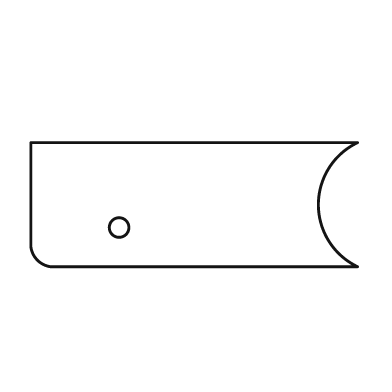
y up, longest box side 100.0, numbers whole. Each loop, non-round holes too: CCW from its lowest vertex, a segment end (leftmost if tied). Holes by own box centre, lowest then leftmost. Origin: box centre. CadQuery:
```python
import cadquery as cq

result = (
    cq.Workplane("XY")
    .moveTo(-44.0, -19.0)
    .lineTo(50.0, -19.0)
    .threePointArc((38.0, 0.0), (50.0, 19.0))
    .lineTo(-50.0, 19.0)
    .lineTo(-50.0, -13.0)
    .threePointArc((-48.0, -17.0), (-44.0, -19.0))
    .close()
    .moveTo(-23.0, -7.0)
    .circle(3.0)
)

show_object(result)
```